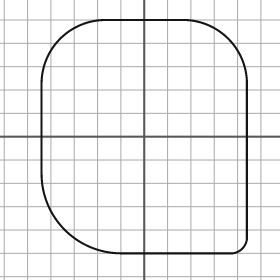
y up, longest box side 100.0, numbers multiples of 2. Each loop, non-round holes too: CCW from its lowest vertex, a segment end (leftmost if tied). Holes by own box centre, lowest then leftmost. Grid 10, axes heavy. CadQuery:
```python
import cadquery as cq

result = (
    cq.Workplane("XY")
    .moveTo(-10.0, -50.0)
    .lineTo(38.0, -50.0)
    .threePointArc((42.0, -48.0), (44.0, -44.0))
    .lineTo(44.0, 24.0)
    .threePointArc((36.0, 42.0), (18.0, 50.0))
    .lineTo(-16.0, 50.0)
    .threePointArc((-36.0, 42.0), (-44.0, 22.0))
    .lineTo(-44.0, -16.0)
    .threePointArc((-34.0, -40.0), (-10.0, -50.0))
    .close()
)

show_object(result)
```